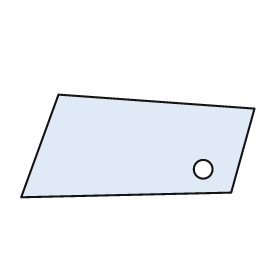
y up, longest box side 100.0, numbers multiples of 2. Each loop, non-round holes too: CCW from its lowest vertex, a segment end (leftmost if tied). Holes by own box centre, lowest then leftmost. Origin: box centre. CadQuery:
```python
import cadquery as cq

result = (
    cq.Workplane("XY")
    .moveTo(-50.0, -22.0)
    .lineTo(40.0, -20.0)
    .lineTo(50.0, 16.0)
    .lineTo(-34.0, 22.0)
    .close()
    .moveTo(28.0, -10.0)
    .circle(4.0)
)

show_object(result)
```